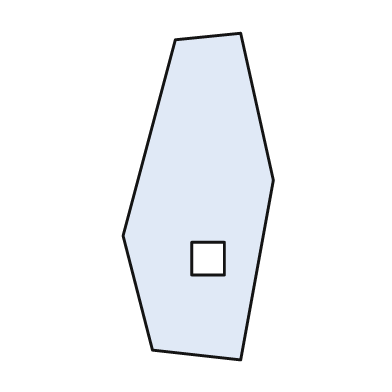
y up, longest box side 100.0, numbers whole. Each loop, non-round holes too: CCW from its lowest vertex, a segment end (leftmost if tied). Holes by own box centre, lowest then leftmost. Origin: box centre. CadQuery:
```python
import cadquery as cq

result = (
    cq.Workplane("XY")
    .moveTo(13.0, -50.0)
    .lineTo(23.0, 5.0)
    .lineTo(13.0, 50.0)
    .lineTo(-7.0, 48.0)
    .lineTo(-23.0, -12.0)
    .lineTo(-14.0, -47.0)
    .close()
    .moveTo(-2.0, -24.0)
    .lineTo(8.0, -24.0)
    .lineTo(8.0, -14.0)
    .lineTo(-2.0, -14.0)
    .close()
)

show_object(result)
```